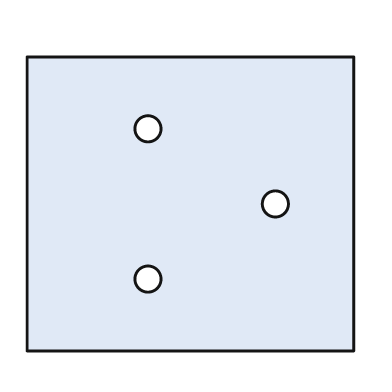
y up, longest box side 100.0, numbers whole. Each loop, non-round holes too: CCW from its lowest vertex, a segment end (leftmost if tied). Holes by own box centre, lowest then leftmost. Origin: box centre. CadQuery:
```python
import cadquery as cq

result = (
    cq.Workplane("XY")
    .moveTo(-50.0, -45.0)
    .lineTo(50.0, -45.0)
    .lineTo(50.0, 45.0)
    .lineTo(-50.0, 45.0)
    .close()
    .moveTo(-13.0, -23.0)
    .circle(4.0)
    .moveTo(26.0, 0.0)
    .circle(4.0)
    .moveTo(-13.0, 23.0)
    .circle(4.0)
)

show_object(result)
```